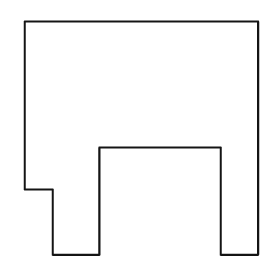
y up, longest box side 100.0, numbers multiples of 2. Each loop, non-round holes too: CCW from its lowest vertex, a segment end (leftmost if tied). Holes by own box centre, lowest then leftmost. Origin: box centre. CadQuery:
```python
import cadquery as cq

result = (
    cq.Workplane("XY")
    .moveTo(-38.0, -50.0)
    .lineTo(-18.0, -50.0)
    .lineTo(-18.0, -4.0)
    .lineTo(34.0, -4.0)
    .lineTo(34.0, -50.0)
    .lineTo(50.0, -50.0)
    .lineTo(50.0, 50.0)
    .lineTo(-50.0, 50.0)
    .lineTo(-50.0, -22.0)
    .lineTo(-38.0, -22.0)
    .close()
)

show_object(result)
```